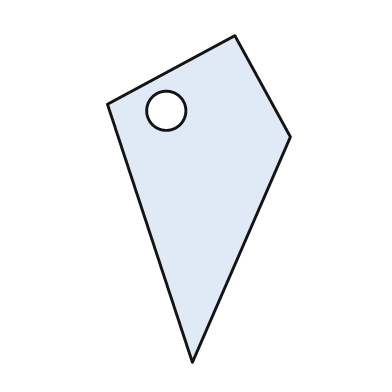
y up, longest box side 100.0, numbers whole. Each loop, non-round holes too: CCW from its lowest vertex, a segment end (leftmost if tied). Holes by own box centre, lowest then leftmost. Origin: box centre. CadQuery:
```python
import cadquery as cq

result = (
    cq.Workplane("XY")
    .moveTo(-2.0, -50.0)
    .lineTo(28.0, 19.0)
    .lineTo(11.0, 50.0)
    .lineTo(-28.0, 29.0)
    .close()
    .moveTo(-10.0, 27.0)
    .circle(6.0)
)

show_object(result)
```